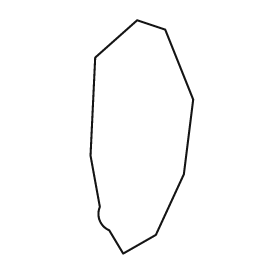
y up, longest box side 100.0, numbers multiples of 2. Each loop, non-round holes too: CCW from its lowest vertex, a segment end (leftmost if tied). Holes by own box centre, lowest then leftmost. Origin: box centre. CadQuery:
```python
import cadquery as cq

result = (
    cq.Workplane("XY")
    .moveTo(-8.0, -50.0)
    .lineTo(6.0, -42.0)
    .lineTo(18.0, -16.0)
    .lineTo(22.0, 16.0)
    .lineTo(10.0, 46.0)
    .lineTo(-2.0, 50.0)
    .lineTo(-20.0, 34.0)
    .lineTo(-22.0, -8.0)
    .lineTo(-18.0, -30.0)
    .threePointArc((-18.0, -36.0), (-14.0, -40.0))
    .close()
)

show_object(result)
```